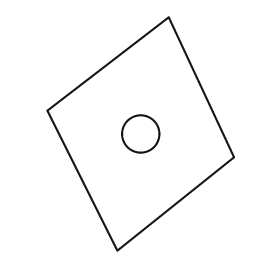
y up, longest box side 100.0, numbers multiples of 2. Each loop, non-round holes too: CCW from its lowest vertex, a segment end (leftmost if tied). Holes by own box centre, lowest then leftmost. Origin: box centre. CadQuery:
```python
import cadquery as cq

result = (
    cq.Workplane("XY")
    .moveTo(-10.0, -50.0)
    .lineTo(40.0, -10.0)
    .lineTo(12.0, 50.0)
    .lineTo(-40.0, 10.0)
    .close()
    .moveTo(0.0, 0.0)
    .circle(8.0)
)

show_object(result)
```